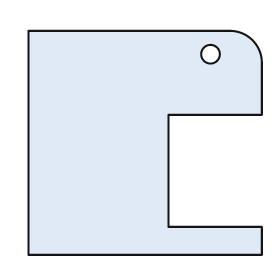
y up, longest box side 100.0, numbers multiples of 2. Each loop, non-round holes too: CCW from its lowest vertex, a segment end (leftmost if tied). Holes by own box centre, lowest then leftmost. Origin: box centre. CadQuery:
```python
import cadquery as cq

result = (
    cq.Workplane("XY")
    .moveTo(-50.0, -48.0)
    .lineTo(50.0, -48.0)
    .lineTo(50.0, -36.0)
    .lineTo(10.0, -36.0)
    .lineTo(10.0, 12.0)
    .lineTo(50.0, 12.0)
    .lineTo(50.0, 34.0)
    .threePointArc((46.0, 44.0), (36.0, 48.0))
    .lineTo(-50.0, 48.0)
    .close()
    .moveTo(28.0, 38.0)
    .circle(4.0)
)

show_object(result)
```